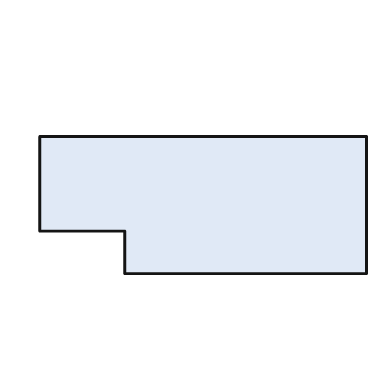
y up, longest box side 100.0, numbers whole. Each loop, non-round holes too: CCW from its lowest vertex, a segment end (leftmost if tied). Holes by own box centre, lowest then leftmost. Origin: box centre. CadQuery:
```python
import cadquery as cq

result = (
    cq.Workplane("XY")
    .moveTo(-24.0, -21.0)
    .lineTo(50.0, -21.0)
    .lineTo(50.0, 21.0)
    .lineTo(-50.0, 21.0)
    .lineTo(-50.0, -8.0)
    .lineTo(-24.0, -8.0)
    .close()
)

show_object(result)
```